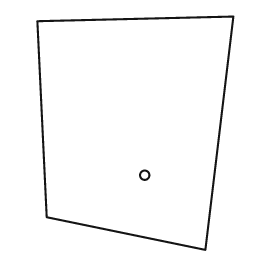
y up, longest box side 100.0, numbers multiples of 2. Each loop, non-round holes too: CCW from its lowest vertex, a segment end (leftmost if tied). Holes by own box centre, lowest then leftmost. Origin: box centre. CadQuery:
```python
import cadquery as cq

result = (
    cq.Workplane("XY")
    .moveTo(30.0, -50.0)
    .lineTo(42.0, 50.0)
    .lineTo(-42.0, 48.0)
    .lineTo(-38.0, -36.0)
    .close()
    .moveTo(4.0, -18.0)
    .circle(2.0)
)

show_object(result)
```